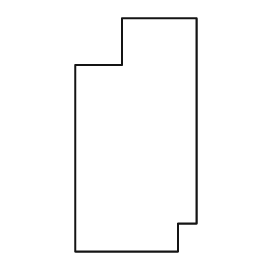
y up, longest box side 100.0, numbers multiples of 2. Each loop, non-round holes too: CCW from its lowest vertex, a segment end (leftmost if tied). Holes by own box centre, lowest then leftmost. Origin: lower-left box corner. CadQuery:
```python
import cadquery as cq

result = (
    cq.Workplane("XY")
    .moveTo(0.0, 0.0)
    .lineTo(44.0, 0.0)
    .lineTo(44.0, 12.0)
    .lineTo(52.0, 12.0)
    .lineTo(52.0, 100.0)
    .lineTo(20.0, 100.0)
    .lineTo(20.0, 80.0)
    .lineTo(0.0, 80.0)
    .close()
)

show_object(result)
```